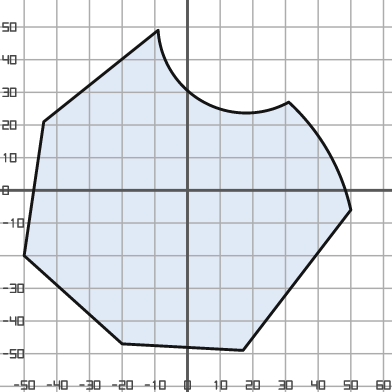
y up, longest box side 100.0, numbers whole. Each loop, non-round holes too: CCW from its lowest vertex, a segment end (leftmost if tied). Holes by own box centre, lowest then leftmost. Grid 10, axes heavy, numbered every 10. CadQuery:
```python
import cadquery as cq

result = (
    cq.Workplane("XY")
    .moveTo(17.0, -49.0)
    .lineTo(50.0, -6.0)
    .threePointArc((43.0, 12.0), (31.0, 27.0))
    .threePointArc((5.0, 27.0), (-9.0, 49.0))
    .lineTo(-44.0, 21.0)
    .lineTo(-50.0, -20.0)
    .lineTo(-20.0, -47.0)
    .close()
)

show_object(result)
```